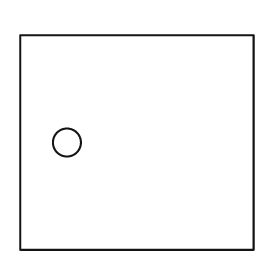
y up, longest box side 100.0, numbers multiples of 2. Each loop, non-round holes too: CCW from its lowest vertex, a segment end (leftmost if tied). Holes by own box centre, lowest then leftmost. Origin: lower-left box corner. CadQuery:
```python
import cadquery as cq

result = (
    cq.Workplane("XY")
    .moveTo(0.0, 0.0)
    .lineTo(100.0, 0.0)
    .lineTo(100.0, 92.0)
    .lineTo(0.0, 92.0)
    .close()
    .moveTo(20.0, 46.0)
    .circle(6.0)
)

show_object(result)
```